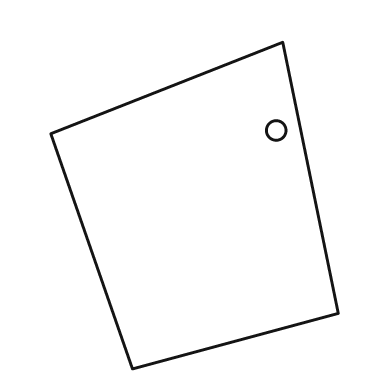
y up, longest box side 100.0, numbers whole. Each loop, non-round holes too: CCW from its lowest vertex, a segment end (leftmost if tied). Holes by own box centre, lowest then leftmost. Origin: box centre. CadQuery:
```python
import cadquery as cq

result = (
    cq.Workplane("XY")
    .moveTo(-19.0, -50.0)
    .lineTo(44.0, -33.0)
    .lineTo(27.0, 50.0)
    .lineTo(-44.0, 22.0)
    .close()
    .moveTo(25.0, 23.0)
    .circle(3.0)
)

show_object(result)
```